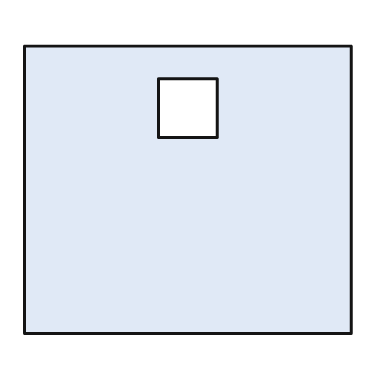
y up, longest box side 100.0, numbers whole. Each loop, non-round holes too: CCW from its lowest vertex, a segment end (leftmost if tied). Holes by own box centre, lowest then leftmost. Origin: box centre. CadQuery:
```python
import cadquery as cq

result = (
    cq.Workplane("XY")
    .moveTo(-50.0, -44.0)
    .lineTo(50.0, -44.0)
    .lineTo(50.0, 44.0)
    .lineTo(-50.0, 44.0)
    .close()
    .moveTo(-9.0, 16.0)
    .lineTo(9.0, 16.0)
    .lineTo(9.0, 34.0)
    .lineTo(-9.0, 34.0)
    .close()
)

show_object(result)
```